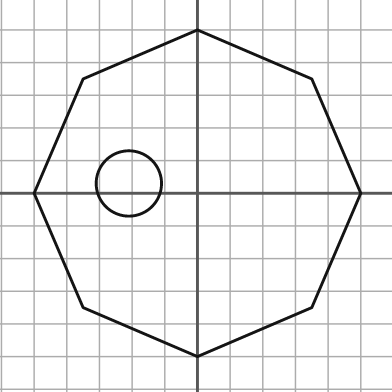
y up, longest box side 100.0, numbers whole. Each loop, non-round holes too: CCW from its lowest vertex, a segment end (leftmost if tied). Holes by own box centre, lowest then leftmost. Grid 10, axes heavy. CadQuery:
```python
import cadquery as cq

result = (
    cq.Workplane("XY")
    .moveTo(0.0, -50.0)
    .lineTo(35.0, -35.0)
    .lineTo(50.0, 0.0)
    .lineTo(35.0, 35.0)
    .lineTo(0.0, 50.0)
    .lineTo(-35.0, 35.0)
    .lineTo(-50.0, 0.0)
    .lineTo(-35.0, -35.0)
    .close()
    .moveTo(-21.0, 3.0)
    .circle(10.0)
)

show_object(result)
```